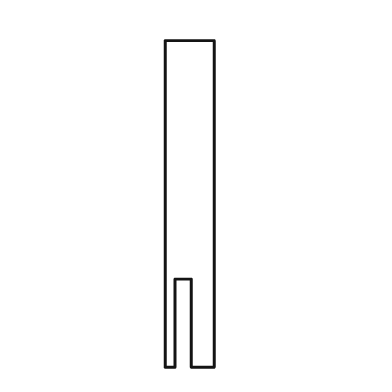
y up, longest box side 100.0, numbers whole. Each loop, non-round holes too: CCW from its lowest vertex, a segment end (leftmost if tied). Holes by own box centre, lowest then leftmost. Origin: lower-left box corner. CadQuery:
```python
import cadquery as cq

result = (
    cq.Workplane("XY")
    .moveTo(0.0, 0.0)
    .lineTo(3.0, 0.0)
    .lineTo(3.0, 27.0)
    .lineTo(8.0, 27.0)
    .lineTo(8.0, 0.0)
    .lineTo(15.0, 0.0)
    .lineTo(15.0, 100.0)
    .lineTo(0.0, 100.0)
    .close()
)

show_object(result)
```